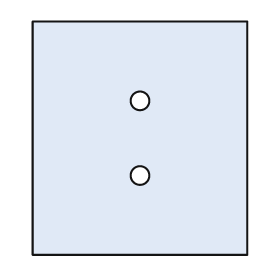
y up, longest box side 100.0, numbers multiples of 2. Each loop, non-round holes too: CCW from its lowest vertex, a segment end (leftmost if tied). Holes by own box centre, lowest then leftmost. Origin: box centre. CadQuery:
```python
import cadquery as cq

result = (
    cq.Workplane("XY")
    .moveTo(-46.0, -50.0)
    .lineTo(46.0, -50.0)
    .lineTo(46.0, 50.0)
    .lineTo(-46.0, 50.0)
    .close()
    .moveTo(0.0, -16.0)
    .circle(4.0)
    .moveTo(0.0, 16.0)
    .circle(4.0)
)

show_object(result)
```